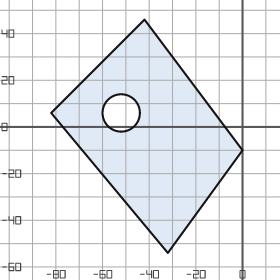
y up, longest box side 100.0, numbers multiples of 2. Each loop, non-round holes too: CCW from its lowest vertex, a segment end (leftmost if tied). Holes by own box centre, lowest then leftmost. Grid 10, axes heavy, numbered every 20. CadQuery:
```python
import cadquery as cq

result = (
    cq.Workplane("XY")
    .moveTo(-32.0, -54.0)
    .lineTo(0.0, -10.0)
    .lineTo(-42.0, 46.0)
    .lineTo(-82.0, 6.0)
    .close()
    .moveTo(-52.0, 6.0)
    .circle(8.0)
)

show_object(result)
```